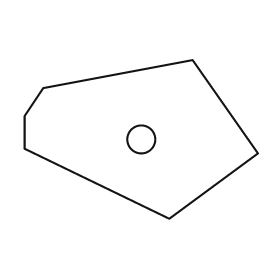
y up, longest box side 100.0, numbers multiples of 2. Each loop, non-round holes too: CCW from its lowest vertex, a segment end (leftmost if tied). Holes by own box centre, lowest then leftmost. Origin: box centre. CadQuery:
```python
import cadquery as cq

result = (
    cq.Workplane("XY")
    .moveTo(12.0, -34.0)
    .lineTo(50.0, -6.0)
    .lineTo(22.0, 34.0)
    .lineTo(-42.0, 22.0)
    .lineTo(-50.0, 10.0)
    .lineTo(-50.0, -4.0)
    .close()
    .moveTo(0.0, 0.0)
    .circle(6.0)
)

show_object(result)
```